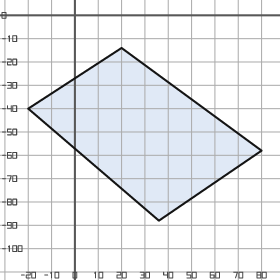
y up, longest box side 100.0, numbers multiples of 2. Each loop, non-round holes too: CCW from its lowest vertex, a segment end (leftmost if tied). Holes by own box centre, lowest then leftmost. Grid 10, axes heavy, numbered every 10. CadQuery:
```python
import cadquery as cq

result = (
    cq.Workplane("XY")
    .moveTo(36.0, -88.0)
    .lineTo(80.0, -58.0)
    .lineTo(20.0, -14.0)
    .lineTo(-20.0, -40.0)
    .close()
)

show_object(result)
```